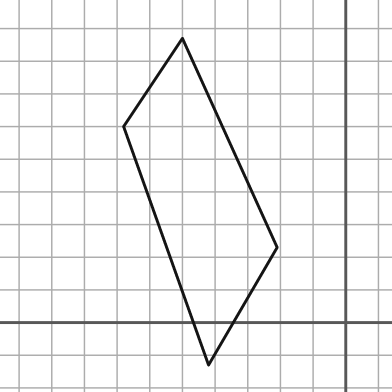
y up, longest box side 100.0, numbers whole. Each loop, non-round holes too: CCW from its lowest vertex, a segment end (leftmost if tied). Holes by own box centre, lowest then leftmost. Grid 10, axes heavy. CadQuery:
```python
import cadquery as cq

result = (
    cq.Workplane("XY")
    .moveTo(-42.0, -13.0)
    .lineTo(-21.0, 23.0)
    .lineTo(-50.0, 87.0)
    .lineTo(-68.0, 60.0)
    .close()
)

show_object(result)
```